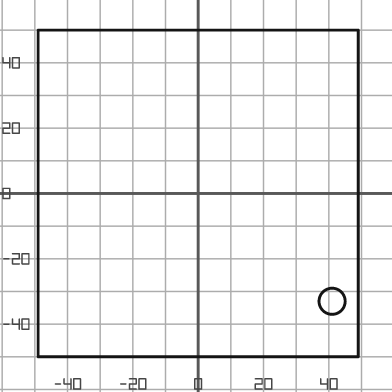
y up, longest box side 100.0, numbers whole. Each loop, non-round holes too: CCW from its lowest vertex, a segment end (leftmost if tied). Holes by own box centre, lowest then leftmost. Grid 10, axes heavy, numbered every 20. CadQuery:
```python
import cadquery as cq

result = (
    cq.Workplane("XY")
    .moveTo(-49.0, -50.0)
    .lineTo(49.0, -50.0)
    .lineTo(49.0, 50.0)
    .lineTo(-49.0, 50.0)
    .close()
    .moveTo(41.0, -33.0)
    .circle(4.0)
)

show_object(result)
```